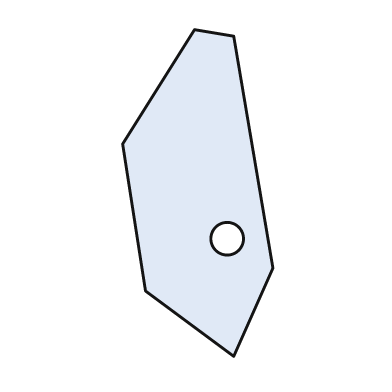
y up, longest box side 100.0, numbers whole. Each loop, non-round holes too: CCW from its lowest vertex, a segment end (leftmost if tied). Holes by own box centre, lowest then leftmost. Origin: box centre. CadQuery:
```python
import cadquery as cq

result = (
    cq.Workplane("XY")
    .moveTo(11.0, -50.0)
    .lineTo(23.0, -23.0)
    .lineTo(11.0, 48.0)
    .lineTo(-1.0, 50.0)
    .lineTo(-23.0, 15.0)
    .lineTo(-16.0, -30.0)
    .close()
    .moveTo(9.0, -14.0)
    .circle(5.0)
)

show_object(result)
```